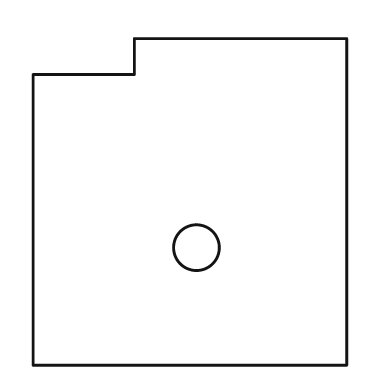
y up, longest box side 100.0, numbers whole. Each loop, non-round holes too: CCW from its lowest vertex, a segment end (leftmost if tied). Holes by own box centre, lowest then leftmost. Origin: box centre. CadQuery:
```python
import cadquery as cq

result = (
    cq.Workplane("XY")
    .moveTo(-48.0, -50.0)
    .lineTo(48.0, -50.0)
    .lineTo(48.0, 50.0)
    .lineTo(-17.0, 50.0)
    .lineTo(-17.0, 39.0)
    .lineTo(-48.0, 39.0)
    .close()
    .moveTo(2.0, -14.0)
    .circle(7.0)
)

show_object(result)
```